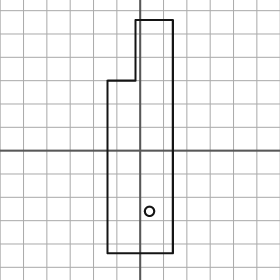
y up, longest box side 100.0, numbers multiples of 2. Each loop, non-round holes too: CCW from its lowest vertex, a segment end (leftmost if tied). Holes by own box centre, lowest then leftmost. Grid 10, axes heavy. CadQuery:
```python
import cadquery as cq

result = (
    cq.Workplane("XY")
    .moveTo(-14.0, -44.0)
    .lineTo(14.0, -44.0)
    .lineTo(14.0, 56.0)
    .lineTo(-2.0, 56.0)
    .lineTo(-2.0, 30.0)
    .lineTo(-14.0, 30.0)
    .close()
    .moveTo(4.0, -26.0)
    .circle(2.0)
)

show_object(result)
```